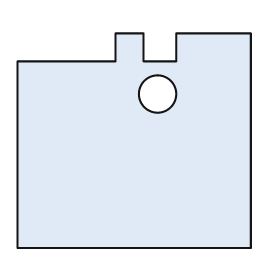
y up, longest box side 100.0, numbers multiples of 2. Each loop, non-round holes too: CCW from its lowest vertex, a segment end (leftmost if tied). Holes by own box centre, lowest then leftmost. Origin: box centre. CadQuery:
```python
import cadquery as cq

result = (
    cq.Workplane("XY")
    .moveTo(-50.0, -46.0)
    .lineTo(50.0, -46.0)
    .lineTo(50.0, 46.0)
    .lineTo(18.0, 46.0)
    .lineTo(18.0, 34.0)
    .lineTo(4.0, 34.0)
    .lineTo(4.0, 46.0)
    .lineTo(-8.0, 46.0)
    .lineTo(-8.0, 34.0)
    .lineTo(-50.0, 34.0)
    .close()
    .moveTo(10.0, 20.0)
    .circle(8.0)
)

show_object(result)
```